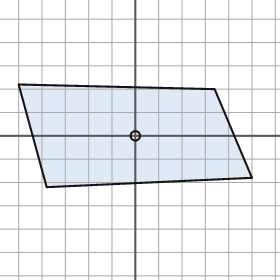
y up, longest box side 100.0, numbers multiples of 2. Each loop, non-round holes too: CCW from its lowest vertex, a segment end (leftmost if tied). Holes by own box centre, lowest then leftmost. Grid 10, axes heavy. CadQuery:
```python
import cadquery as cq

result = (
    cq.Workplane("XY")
    .moveTo(-38.0, -22.0)
    .lineTo(50.0, -18.0)
    .lineTo(34.0, 20.0)
    .lineTo(-50.0, 22.0)
    .close()
    .moveTo(0.0, 0.0)
    .circle(2.0)
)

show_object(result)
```